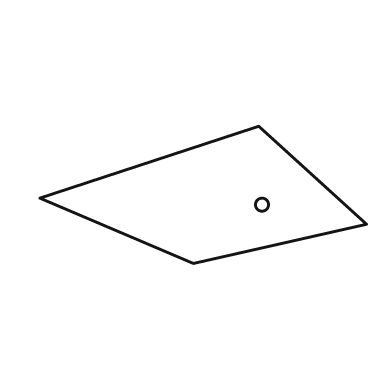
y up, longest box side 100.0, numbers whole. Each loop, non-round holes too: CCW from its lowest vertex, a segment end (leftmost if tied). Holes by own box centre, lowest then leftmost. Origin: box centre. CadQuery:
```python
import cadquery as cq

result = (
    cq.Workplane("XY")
    .moveTo(-3.0, -21.0)
    .lineTo(50.0, -9.0)
    .lineTo(17.0, 21.0)
    .lineTo(-50.0, -1.0)
    .close()
    .moveTo(18.0, -3.0)
    .circle(2.0)
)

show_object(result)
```